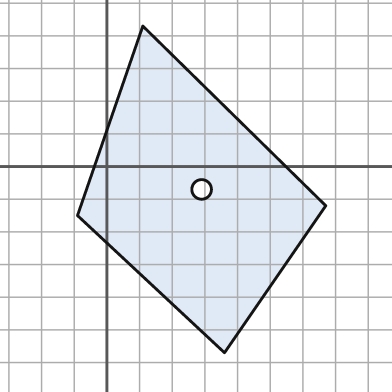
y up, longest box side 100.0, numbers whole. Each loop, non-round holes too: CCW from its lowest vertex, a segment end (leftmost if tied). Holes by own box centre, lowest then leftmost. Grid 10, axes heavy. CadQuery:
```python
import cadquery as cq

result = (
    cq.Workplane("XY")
    .moveTo(36.0, -57.0)
    .lineTo(67.0, -12.0)
    .lineTo(11.0, 43.0)
    .lineTo(-9.0, -15.0)
    .close()
    .moveTo(29.0, -7.0)
    .circle(3.0)
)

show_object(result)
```